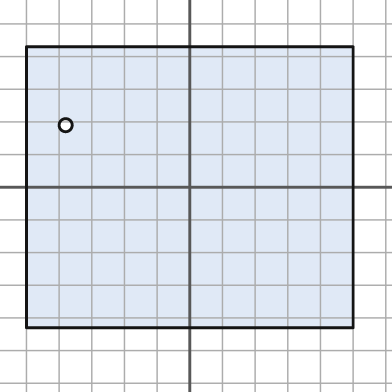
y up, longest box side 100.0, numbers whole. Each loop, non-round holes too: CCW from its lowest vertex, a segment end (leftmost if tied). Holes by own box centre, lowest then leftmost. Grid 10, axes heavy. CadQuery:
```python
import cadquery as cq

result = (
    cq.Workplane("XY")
    .moveTo(-50.0, -43.0)
    .lineTo(50.0, -43.0)
    .lineTo(50.0, 43.0)
    .lineTo(-50.0, 43.0)
    .close()
    .moveTo(-38.0, 19.0)
    .circle(2.0)
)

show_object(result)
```